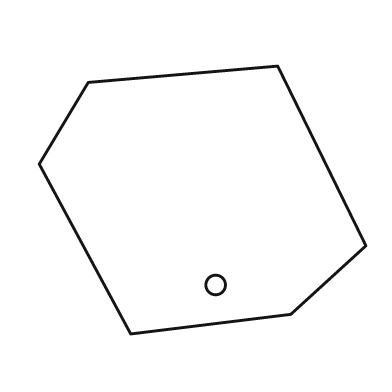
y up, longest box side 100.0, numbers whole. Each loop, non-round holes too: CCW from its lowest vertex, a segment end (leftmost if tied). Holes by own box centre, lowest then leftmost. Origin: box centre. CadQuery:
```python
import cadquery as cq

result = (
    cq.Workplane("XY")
    .moveTo(-22.0, -41.0)
    .lineTo(27.0, -35.0)
    .lineTo(50.0, -14.0)
    .lineTo(23.0, 41.0)
    .lineTo(-35.0, 36.0)
    .lineTo(-50.0, 11.0)
    .close()
    .moveTo(4.0, -26.0)
    .circle(3.0)
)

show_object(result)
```